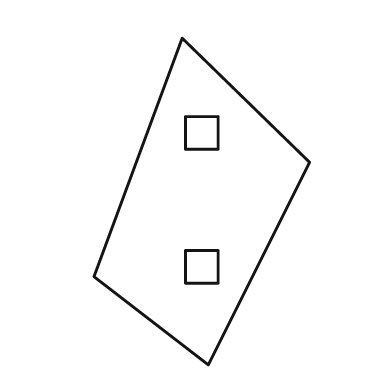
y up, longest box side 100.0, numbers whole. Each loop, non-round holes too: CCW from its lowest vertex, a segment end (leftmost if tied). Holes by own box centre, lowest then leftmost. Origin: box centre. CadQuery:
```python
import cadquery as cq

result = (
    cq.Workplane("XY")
    .moveTo(2.0, -50.0)
    .lineTo(33.0, 12.0)
    .lineTo(-6.0, 50.0)
    .lineTo(-33.0, -23.0)
    .close()
    .moveTo(-5.0, -25.0)
    .lineTo(5.0, -25.0)
    .lineTo(5.0, -15.0)
    .lineTo(-5.0, -15.0)
    .close()
    .moveTo(-5.0, 16.0)
    .lineTo(5.0, 16.0)
    .lineTo(5.0, 26.0)
    .lineTo(-5.0, 26.0)
    .close()
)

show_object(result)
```